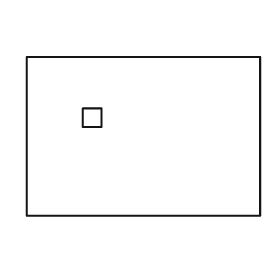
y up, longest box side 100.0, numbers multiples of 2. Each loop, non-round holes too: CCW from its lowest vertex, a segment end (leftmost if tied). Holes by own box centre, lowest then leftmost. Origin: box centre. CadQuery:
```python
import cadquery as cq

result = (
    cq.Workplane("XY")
    .moveTo(-50.0, -34.0)
    .lineTo(50.0, -34.0)
    .lineTo(50.0, 34.0)
    .lineTo(-50.0, 34.0)
    .close()
    .moveTo(-26.0, 4.0)
    .lineTo(-18.0, 4.0)
    .lineTo(-18.0, 12.0)
    .lineTo(-26.0, 12.0)
    .close()
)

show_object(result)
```